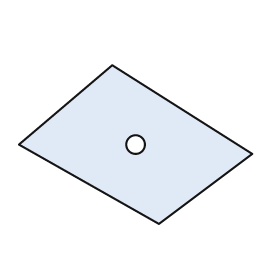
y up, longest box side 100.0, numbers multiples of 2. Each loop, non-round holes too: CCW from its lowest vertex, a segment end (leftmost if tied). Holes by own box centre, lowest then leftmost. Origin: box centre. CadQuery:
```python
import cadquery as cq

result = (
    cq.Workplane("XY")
    .moveTo(10.0, -34.0)
    .lineTo(50.0, -4.0)
    .lineTo(-10.0, 34.0)
    .lineTo(-50.0, 0.0)
    .close()
    .moveTo(0.0, 0.0)
    .circle(4.0)
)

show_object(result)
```